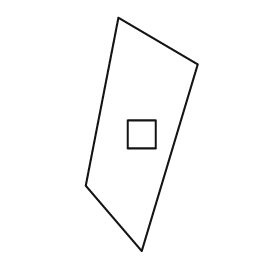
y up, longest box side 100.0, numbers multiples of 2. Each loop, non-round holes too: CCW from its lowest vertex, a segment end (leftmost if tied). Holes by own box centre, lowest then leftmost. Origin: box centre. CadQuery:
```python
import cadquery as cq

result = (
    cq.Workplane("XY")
    .moveTo(0.0, -50.0)
    .lineTo(24.0, 30.0)
    .lineTo(-10.0, 50.0)
    .lineTo(-24.0, -22.0)
    .close()
    .moveTo(-6.0, -6.0)
    .lineTo(6.0, -6.0)
    .lineTo(6.0, 6.0)
    .lineTo(-6.0, 6.0)
    .close()
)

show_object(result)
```